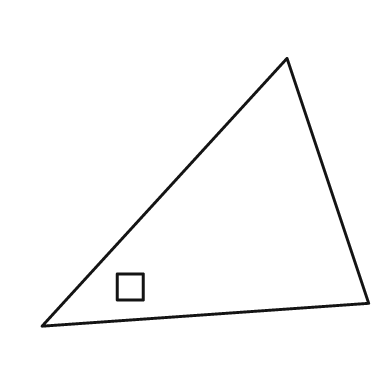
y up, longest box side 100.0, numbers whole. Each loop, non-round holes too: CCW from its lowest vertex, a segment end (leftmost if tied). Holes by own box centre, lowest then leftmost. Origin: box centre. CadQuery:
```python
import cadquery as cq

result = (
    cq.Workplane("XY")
    .moveTo(-50.0, -41.0)
    .lineTo(50.0, -34.0)
    .lineTo(25.0, 41.0)
    .close()
    .moveTo(-27.0, -33.0)
    .lineTo(-19.0, -33.0)
    .lineTo(-19.0, -25.0)
    .lineTo(-27.0, -25.0)
    .close()
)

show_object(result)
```